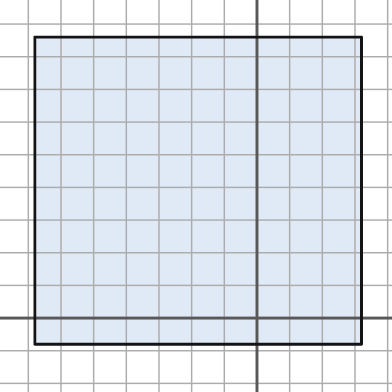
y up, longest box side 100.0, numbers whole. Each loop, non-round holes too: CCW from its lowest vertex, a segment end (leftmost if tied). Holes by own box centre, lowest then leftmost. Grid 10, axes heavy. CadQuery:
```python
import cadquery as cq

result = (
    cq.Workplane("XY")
    .moveTo(-68.0, -8.0)
    .lineTo(32.0, -8.0)
    .lineTo(32.0, 86.0)
    .lineTo(-68.0, 86.0)
    .close()
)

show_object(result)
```